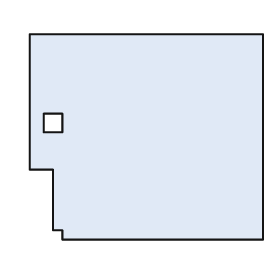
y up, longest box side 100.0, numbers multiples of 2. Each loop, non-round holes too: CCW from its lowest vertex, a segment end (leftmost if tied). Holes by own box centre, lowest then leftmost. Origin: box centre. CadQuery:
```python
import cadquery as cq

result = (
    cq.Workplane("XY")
    .moveTo(-36.0, -44.0)
    .lineTo(50.0, -44.0)
    .lineTo(50.0, 44.0)
    .lineTo(-50.0, 44.0)
    .lineTo(-50.0, -14.0)
    .lineTo(-40.0, -14.0)
    .lineTo(-40.0, -40.0)
    .lineTo(-36.0, -40.0)
    .close()
    .moveTo(-44.0, 2.0)
    .lineTo(-36.0, 2.0)
    .lineTo(-36.0, 10.0)
    .lineTo(-44.0, 10.0)
    .close()
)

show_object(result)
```